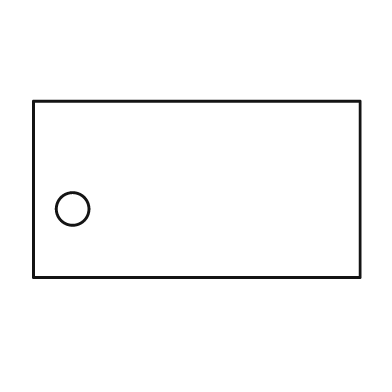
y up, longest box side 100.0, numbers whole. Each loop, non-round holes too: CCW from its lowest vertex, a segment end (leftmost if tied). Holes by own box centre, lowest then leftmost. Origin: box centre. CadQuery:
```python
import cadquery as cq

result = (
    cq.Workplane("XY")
    .moveTo(-50.0, -27.0)
    .lineTo(50.0, -27.0)
    .lineTo(50.0, 27.0)
    .lineTo(-50.0, 27.0)
    .close()
    .moveTo(-38.0, -6.0)
    .circle(5.0)
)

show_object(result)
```